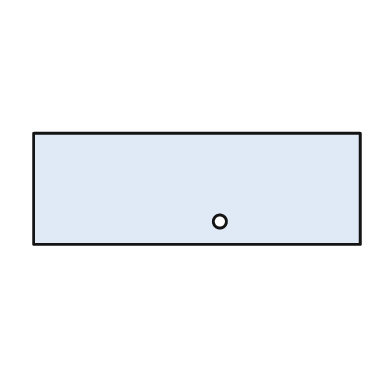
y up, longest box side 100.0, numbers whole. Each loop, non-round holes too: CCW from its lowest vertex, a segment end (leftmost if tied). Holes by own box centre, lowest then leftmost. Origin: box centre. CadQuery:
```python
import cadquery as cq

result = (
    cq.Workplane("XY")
    .moveTo(-50.0, -17.0)
    .lineTo(50.0, -17.0)
    .lineTo(50.0, 17.0)
    .lineTo(-50.0, 17.0)
    .close()
    .moveTo(7.0, -10.0)
    .circle(2.0)
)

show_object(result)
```